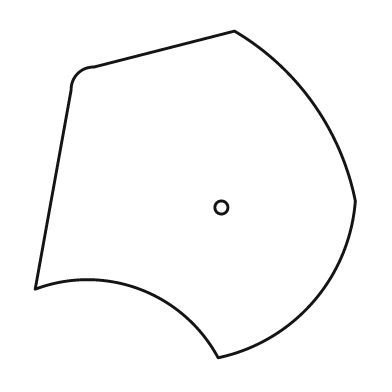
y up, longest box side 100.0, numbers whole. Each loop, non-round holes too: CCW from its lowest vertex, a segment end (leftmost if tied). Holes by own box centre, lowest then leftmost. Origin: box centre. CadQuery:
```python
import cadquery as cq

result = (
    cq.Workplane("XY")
    .moveTo(7.0, -50.0)
    .threePointArc((36.0, -33.0), (49.0, -2.0))
    .threePointArc((36.0, 28.0), (12.0, 50.0))
    .lineTo(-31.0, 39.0)
    .threePointArc((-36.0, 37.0), (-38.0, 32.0))
    .lineTo(-49.0, -29.0)
    .threePointArc((-17.0, -29.0), (7.0, -50.0))
    .close()
    .moveTo(8.0, -4.0)
    .circle(2.0)
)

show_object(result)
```